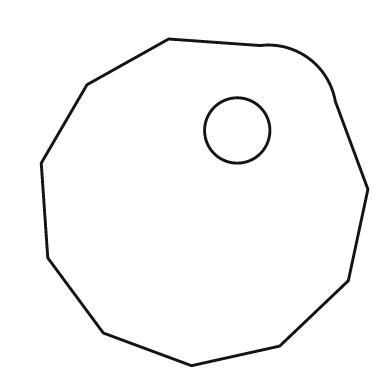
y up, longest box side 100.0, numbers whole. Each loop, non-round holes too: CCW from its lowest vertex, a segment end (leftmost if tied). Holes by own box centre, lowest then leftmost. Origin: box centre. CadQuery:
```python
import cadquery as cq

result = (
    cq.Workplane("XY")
    .moveTo(-4.0, -50.0)
    .lineTo(23.0, -44.0)
    .lineTo(44.0, -24.0)
    .lineTo(50.0, 4.0)
    .lineTo(40.0, 31.0)
    .threePointArc((32.0, 44.0), (17.0, 48.0))
    .lineTo(-11.0, 50.0)
    .lineTo(-36.0, 36.0)
    .lineTo(-50.0, 12.0)
    .lineTo(-48.0, -17.0)
    .lineTo(-31.0, -40.0)
    .close()
    .moveTo(10.0, 22.0)
    .circle(10.0)
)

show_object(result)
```